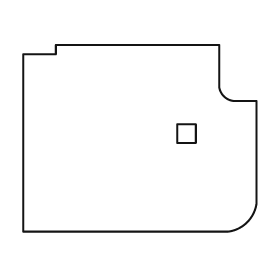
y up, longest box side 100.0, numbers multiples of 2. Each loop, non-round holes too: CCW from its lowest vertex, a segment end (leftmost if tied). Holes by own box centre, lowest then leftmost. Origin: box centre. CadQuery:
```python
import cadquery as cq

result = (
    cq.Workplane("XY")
    .moveTo(-50.0, -40.0)
    .lineTo(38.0, -40.0)
    .threePointArc((46.0, -36.0), (50.0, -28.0))
    .lineTo(50.0, 16.0)
    .lineTo(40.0, 16.0)
    .threePointArc((36.0, 18.0), (34.0, 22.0))
    .lineTo(34.0, 40.0)
    .lineTo(-36.0, 40.0)
    .lineTo(-36.0, 36.0)
    .lineTo(-50.0, 36.0)
    .close()
    .moveTo(16.0, -2.0)
    .lineTo(24.0, -2.0)
    .lineTo(24.0, 6.0)
    .lineTo(16.0, 6.0)
    .close()
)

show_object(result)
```